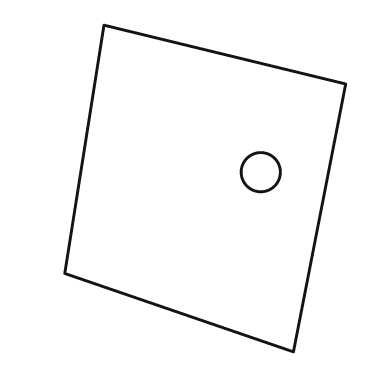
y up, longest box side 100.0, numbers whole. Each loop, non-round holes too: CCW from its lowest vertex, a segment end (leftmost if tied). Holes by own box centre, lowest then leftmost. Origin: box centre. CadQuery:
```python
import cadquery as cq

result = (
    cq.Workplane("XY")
    .moveTo(27.0, -50.0)
    .lineTo(43.0, 32.0)
    .lineTo(-31.0, 50.0)
    .lineTo(-43.0, -26.0)
    .close()
    .moveTo(17.0, 5.0)
    .circle(6.0)
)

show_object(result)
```